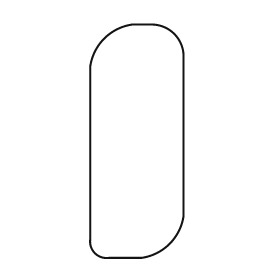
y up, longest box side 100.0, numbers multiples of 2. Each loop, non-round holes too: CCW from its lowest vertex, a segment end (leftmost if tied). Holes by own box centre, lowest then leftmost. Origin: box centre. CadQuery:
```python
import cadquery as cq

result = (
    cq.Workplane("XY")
    .moveTo(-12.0, -50.0)
    .lineTo(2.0, -50.0)
    .threePointArc((14.0, -44.0), (20.0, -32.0))
    .lineTo(20.0, 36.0)
    .threePointArc((16.0, 46.0), (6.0, 50.0))
    .lineTo(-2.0, 50.0)
    .threePointArc((-14.0, 44.0), (-20.0, 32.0))
    .lineTo(-20.0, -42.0)
    .threePointArc((-18.0, -48.0), (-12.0, -50.0))
    .close()
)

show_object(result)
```